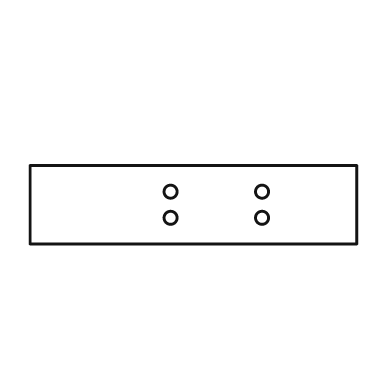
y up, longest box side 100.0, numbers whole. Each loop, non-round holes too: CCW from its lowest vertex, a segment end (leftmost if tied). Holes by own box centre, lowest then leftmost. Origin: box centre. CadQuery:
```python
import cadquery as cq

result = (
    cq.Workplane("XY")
    .moveTo(-50.0, -12.0)
    .lineTo(50.0, -12.0)
    .lineTo(50.0, 12.0)
    .lineTo(-50.0, 12.0)
    .close()
    .moveTo(-7.0, -4.0)
    .circle(2.0)
    .moveTo(21.0, -4.0)
    .circle(2.0)
    .moveTo(-7.0, 4.0)
    .circle(2.0)
    .moveTo(21.0, 4.0)
    .circle(2.0)
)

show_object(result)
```